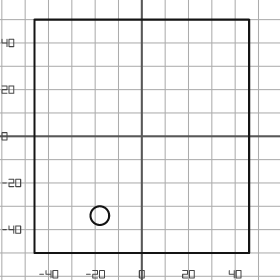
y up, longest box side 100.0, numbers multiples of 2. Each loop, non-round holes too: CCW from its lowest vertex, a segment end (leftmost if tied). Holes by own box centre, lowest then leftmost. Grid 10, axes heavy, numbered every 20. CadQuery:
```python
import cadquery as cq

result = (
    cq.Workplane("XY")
    .moveTo(-46.0, -50.0)
    .lineTo(46.0, -50.0)
    .lineTo(46.0, 50.0)
    .lineTo(-46.0, 50.0)
    .close()
    .moveTo(-18.0, -34.0)
    .circle(4.0)
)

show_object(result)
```